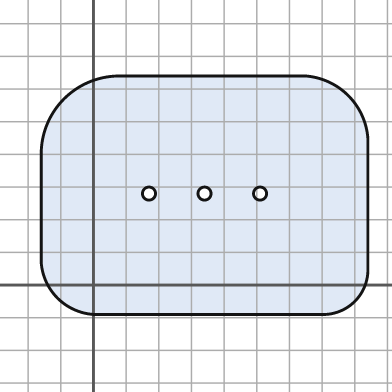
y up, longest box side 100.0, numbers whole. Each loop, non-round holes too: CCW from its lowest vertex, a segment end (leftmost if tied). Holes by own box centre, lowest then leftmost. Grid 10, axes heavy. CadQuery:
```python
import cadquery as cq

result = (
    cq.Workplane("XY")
    .moveTo(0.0, -9.0)
    .lineTo(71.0, -9.0)
    .threePointArc((80.0, -5.0), (84.0, 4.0))
    .lineTo(84.0, 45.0)
    .threePointArc((78.0, 58.0), (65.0, 64.0))
    .lineTo(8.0, 64.0)
    .threePointArc((-9.0, 57.0), (-16.0, 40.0))
    .lineTo(-16.0, 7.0)
    .threePointArc((-11.0, -4.0), (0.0, -9.0))
    .close()
    .moveTo(17.0, 28.0)
    .circle(2.0)
    .moveTo(34.0, 28.0)
    .circle(2.0)
    .moveTo(51.0, 28.0)
    .circle(2.0)
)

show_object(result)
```